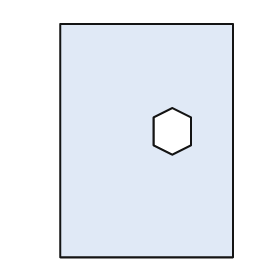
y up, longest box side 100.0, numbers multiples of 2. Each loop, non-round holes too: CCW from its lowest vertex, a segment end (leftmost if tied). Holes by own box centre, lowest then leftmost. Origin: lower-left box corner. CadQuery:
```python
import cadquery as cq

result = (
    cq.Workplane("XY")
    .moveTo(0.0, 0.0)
    .lineTo(74.0, 0.0)
    .lineTo(74.0, 100.0)
    .lineTo(0.0, 100.0)
    .close()
    .moveTo(48.0, 44.0)
    .lineTo(56.0, 48.0)
    .lineTo(56.0, 60.0)
    .lineTo(48.0, 64.0)
    .lineTo(40.0, 60.0)
    .lineTo(40.0, 48.0)
    .close()
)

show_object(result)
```